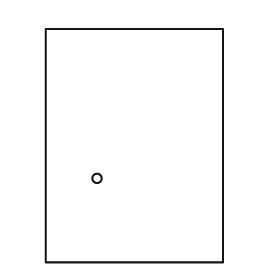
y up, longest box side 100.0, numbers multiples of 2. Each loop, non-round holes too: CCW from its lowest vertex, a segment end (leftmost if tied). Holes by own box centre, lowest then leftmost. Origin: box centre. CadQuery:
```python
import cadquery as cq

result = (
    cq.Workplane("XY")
    .moveTo(-38.0, -50.0)
    .lineTo(38.0, -50.0)
    .lineTo(38.0, 50.0)
    .lineTo(-38.0, 50.0)
    .close()
    .moveTo(-16.0, -14.0)
    .circle(2.0)
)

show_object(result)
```